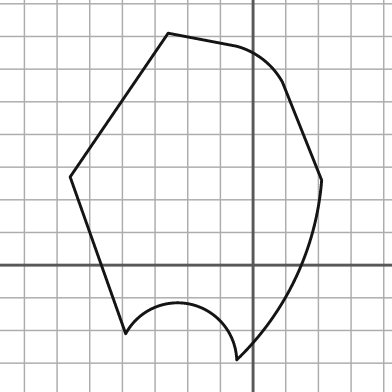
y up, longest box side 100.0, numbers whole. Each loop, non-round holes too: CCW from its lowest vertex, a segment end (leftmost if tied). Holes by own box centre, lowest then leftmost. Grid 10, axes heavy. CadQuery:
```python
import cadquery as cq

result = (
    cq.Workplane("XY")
    .moveTo(-5.0, -29.0)
    .threePointArc((13.0, -4.0), (21.0, 26.0))
    .lineTo(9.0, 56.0)
    .threePointArc((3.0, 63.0), (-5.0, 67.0))
    .lineTo(-26.0, 71.0)
    .lineTo(-56.0, 27.0)
    .lineTo(-39.0, -21.0)
    .threePointArc((-19.0, -12.0), (-5.0, -29.0))
    .close()
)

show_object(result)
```